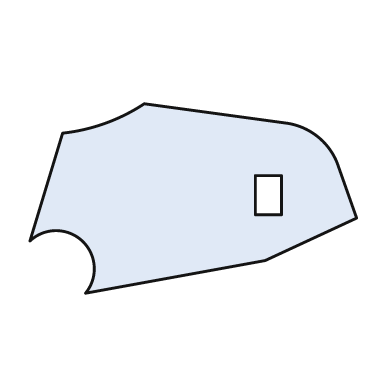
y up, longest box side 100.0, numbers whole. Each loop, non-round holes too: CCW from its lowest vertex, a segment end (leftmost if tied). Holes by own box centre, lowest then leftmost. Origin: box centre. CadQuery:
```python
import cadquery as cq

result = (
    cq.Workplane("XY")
    .moveTo(-33.0, -29.0)
    .lineTo(22.0, -19.0)
    .lineTo(50.0, -6.0)
    .lineTo(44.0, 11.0)
    .threePointArc((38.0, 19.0), (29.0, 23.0))
    .lineTo(-15.0, 29.0)
    .threePointArc((-27.0, 23.0), (-40.0, 20.0))
    .lineTo(-50.0, -13.0)
    .threePointArc((-34.0, -13.0), (-33.0, -29.0))
    .close()
    .moveTo(19.0, -5.0)
    .lineTo(27.0, -5.0)
    .lineTo(27.0, 7.0)
    .lineTo(19.0, 7.0)
    .close()
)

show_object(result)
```